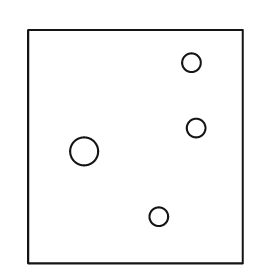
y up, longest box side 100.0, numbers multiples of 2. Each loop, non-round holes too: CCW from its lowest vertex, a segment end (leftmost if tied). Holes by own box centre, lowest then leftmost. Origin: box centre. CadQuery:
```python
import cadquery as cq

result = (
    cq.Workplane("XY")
    .moveTo(-46.0, -50.0)
    .lineTo(46.0, -50.0)
    .lineTo(46.0, 50.0)
    .lineTo(-46.0, 50.0)
    .close()
    .moveTo(10.0, -30.0)
    .circle(4.0)
    .moveTo(-22.0, -2.0)
    .circle(6.0)
    .moveTo(26.0, 8.0)
    .circle(4.0)
    .moveTo(24.0, 36.0)
    .circle(4.0)
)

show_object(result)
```